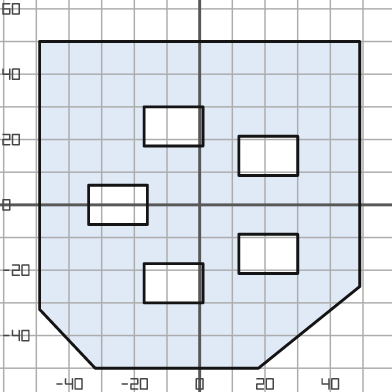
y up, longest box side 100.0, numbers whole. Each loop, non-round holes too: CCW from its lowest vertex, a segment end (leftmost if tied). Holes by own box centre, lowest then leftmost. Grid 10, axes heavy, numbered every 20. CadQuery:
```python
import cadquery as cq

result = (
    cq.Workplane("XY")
    .moveTo(-32.0, -50.0)
    .lineTo(18.0, -50.0)
    .lineTo(49.0, -25.0)
    .lineTo(49.0, 50.0)
    .lineTo(-49.0, 50.0)
    .lineTo(-49.0, -32.0)
    .close()
    .moveTo(-17.0, -30.0)
    .lineTo(1.0, -30.0)
    .lineTo(1.0, -18.0)
    .lineTo(-17.0, -18.0)
    .close()
    .moveTo(12.0, -21.0)
    .lineTo(30.0, -21.0)
    .lineTo(30.0, -9.0)
    .lineTo(12.0, -9.0)
    .close()
    .moveTo(-34.0, -6.0)
    .lineTo(-16.0, -6.0)
    .lineTo(-16.0, 6.0)
    .lineTo(-34.0, 6.0)
    .close()
    .moveTo(12.0, 9.0)
    .lineTo(30.0, 9.0)
    .lineTo(30.0, 21.0)
    .lineTo(12.0, 21.0)
    .close()
    .moveTo(-17.0, 18.0)
    .lineTo(1.0, 18.0)
    .lineTo(1.0, 30.0)
    .lineTo(-17.0, 30.0)
    .close()
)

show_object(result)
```